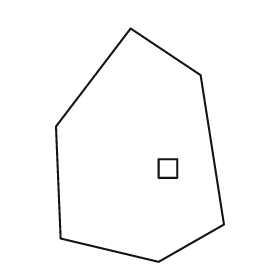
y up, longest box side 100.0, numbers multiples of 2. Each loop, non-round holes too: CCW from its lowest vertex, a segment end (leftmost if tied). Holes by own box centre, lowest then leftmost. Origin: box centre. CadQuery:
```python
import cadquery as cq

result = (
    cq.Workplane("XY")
    .moveTo(8.0, -50.0)
    .lineTo(36.0, -34.0)
    .lineTo(26.0, 30.0)
    .lineTo(-4.0, 50.0)
    .lineTo(-36.0, 8.0)
    .lineTo(-34.0, -40.0)
    .close()
    .moveTo(8.0, -14.0)
    .lineTo(16.0, -14.0)
    .lineTo(16.0, -6.0)
    .lineTo(8.0, -6.0)
    .close()
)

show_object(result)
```